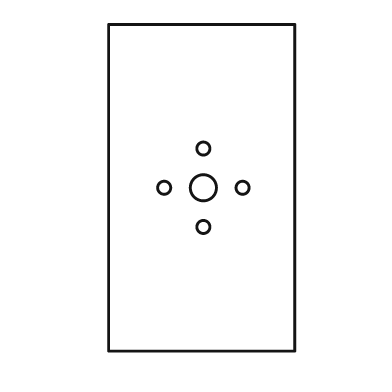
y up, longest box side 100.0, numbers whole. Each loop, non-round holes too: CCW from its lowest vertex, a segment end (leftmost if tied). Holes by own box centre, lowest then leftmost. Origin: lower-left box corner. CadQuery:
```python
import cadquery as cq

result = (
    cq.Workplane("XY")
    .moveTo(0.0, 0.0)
    .lineTo(57.0, 0.0)
    .lineTo(57.0, 100.0)
    .lineTo(0.0, 100.0)
    .close()
    .moveTo(29.0, 38.0)
    .circle(2.0)
    .moveTo(17.0, 50.0)
    .circle(2.0)
    .moveTo(29.0, 50.0)
    .circle(4.0)
    .moveTo(41.0, 50.0)
    .circle(2.0)
    .moveTo(29.0, 62.0)
    .circle(2.0)
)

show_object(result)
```